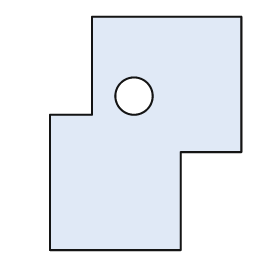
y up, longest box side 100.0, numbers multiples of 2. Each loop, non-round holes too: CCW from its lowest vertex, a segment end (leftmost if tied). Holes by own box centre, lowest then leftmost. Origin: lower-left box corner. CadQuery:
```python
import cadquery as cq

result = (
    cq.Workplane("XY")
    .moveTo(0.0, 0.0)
    .lineTo(56.0, 0.0)
    .lineTo(56.0, 42.0)
    .lineTo(82.0, 42.0)
    .lineTo(82.0, 100.0)
    .lineTo(18.0, 100.0)
    .lineTo(18.0, 58.0)
    .lineTo(0.0, 58.0)
    .close()
    .moveTo(36.0, 66.0)
    .circle(8.0)
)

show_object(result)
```